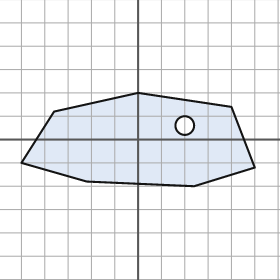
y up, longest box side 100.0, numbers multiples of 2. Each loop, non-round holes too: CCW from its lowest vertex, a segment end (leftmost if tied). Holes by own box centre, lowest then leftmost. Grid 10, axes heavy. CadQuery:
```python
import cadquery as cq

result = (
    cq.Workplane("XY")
    .moveTo(24.0, -20.0)
    .lineTo(50.0, -12.0)
    .lineTo(40.0, 14.0)
    .lineTo(0.0, 20.0)
    .lineTo(-36.0, 12.0)
    .lineTo(-50.0, -10.0)
    .lineTo(-22.0, -18.0)
    .close()
    .moveTo(20.0, 6.0)
    .circle(4.0)
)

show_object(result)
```